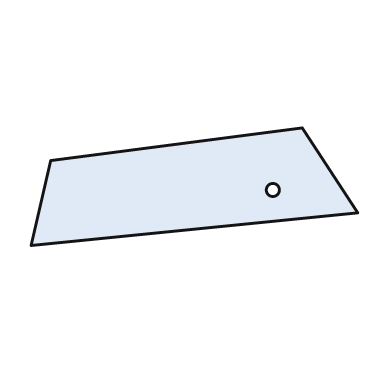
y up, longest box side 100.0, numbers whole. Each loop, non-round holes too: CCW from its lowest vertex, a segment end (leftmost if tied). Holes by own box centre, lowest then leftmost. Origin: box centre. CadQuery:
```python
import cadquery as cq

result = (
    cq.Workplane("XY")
    .moveTo(-50.0, -18.0)
    .lineTo(50.0, -8.0)
    .lineTo(33.0, 18.0)
    .lineTo(-44.0, 8.0)
    .close()
    .moveTo(24.0, -1.0)
    .circle(2.0)
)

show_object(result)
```